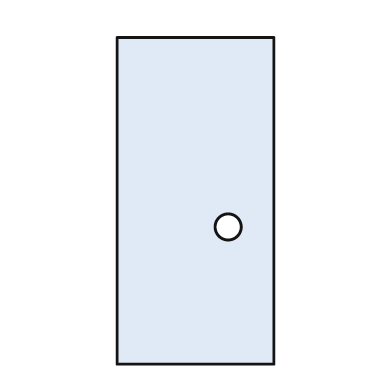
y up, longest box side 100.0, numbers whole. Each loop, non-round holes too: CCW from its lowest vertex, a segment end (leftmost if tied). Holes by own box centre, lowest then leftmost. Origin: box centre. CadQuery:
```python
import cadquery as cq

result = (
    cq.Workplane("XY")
    .moveTo(-24.0, -50.0)
    .lineTo(24.0, -50.0)
    .lineTo(24.0, 50.0)
    .lineTo(-24.0, 50.0)
    .close()
    .moveTo(10.0, -8.0)
    .circle(4.0)
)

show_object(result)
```